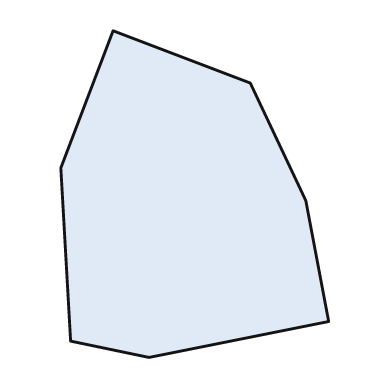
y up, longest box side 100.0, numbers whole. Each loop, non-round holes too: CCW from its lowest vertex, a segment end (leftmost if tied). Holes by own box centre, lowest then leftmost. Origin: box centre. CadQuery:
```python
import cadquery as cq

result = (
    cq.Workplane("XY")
    .moveTo(-14.0, -50.0)
    .lineTo(41.0, -39.0)
    .lineTo(34.0, -2.0)
    .lineTo(17.0, 34.0)
    .lineTo(-25.0, 50.0)
    .lineTo(-41.0, 8.0)
    .lineTo(-38.0, -45.0)
    .close()
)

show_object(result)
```